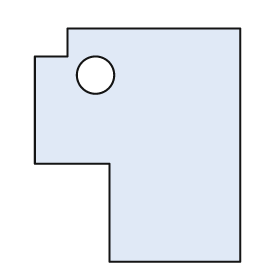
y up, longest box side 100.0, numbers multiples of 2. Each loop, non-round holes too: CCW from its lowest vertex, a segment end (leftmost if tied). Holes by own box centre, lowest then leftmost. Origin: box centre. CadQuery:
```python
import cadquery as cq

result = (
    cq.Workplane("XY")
    .moveTo(-12.0, -50.0)
    .lineTo(44.0, -50.0)
    .lineTo(44.0, 50.0)
    .lineTo(-30.0, 50.0)
    .lineTo(-30.0, 38.0)
    .lineTo(-44.0, 38.0)
    .lineTo(-44.0, -8.0)
    .lineTo(-12.0, -8.0)
    .close()
    .moveTo(-18.0, 30.0)
    .circle(8.0)
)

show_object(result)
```